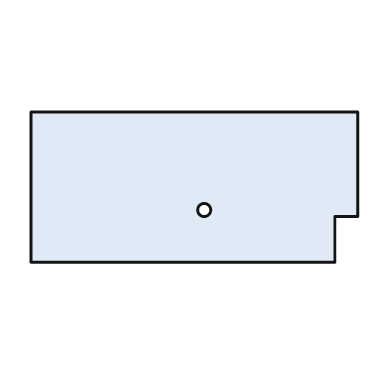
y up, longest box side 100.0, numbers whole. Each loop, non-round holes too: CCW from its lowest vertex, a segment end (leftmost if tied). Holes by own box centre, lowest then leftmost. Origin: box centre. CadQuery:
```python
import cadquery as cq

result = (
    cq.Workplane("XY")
    .moveTo(-50.0, -23.0)
    .lineTo(43.0, -23.0)
    .lineTo(43.0, -9.0)
    .lineTo(50.0, -9.0)
    .lineTo(50.0, 23.0)
    .lineTo(-50.0, 23.0)
    .close()
    .moveTo(3.0, -7.0)
    .circle(2.0)
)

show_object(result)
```